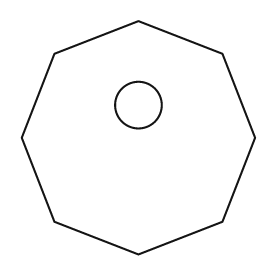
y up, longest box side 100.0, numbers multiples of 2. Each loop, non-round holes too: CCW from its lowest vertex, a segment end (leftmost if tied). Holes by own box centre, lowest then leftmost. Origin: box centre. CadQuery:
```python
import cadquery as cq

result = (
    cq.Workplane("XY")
    .moveTo(0.0, -50.0)
    .lineTo(36.0, -36.0)
    .lineTo(50.0, 0.0)
    .lineTo(36.0, 36.0)
    .lineTo(0.0, 50.0)
    .lineTo(-36.0, 36.0)
    .lineTo(-50.0, 0.0)
    .lineTo(-36.0, -36.0)
    .close()
    .moveTo(0.0, 14.0)
    .circle(10.0)
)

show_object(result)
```